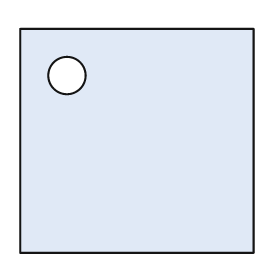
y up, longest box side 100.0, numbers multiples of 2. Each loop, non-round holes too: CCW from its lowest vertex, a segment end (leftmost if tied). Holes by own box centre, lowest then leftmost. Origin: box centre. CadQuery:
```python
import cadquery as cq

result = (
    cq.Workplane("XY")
    .moveTo(-50.0, -48.0)
    .lineTo(50.0, -48.0)
    .lineTo(50.0, 48.0)
    .lineTo(-50.0, 48.0)
    .close()
    .moveTo(-30.0, 28.0)
    .circle(8.0)
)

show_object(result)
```